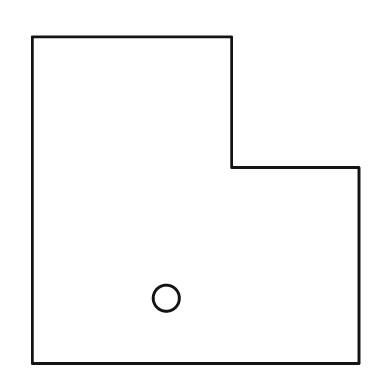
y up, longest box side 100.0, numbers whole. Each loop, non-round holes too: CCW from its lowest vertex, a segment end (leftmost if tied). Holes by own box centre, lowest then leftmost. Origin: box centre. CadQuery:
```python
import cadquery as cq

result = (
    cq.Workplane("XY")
    .moveTo(-50.0, -50.0)
    .lineTo(50.0, -50.0)
    .lineTo(50.0, 10.0)
    .lineTo(11.0, 10.0)
    .lineTo(11.0, 50.0)
    .lineTo(-50.0, 50.0)
    .close()
    .moveTo(-9.0, -30.0)
    .circle(4.0)
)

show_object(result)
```